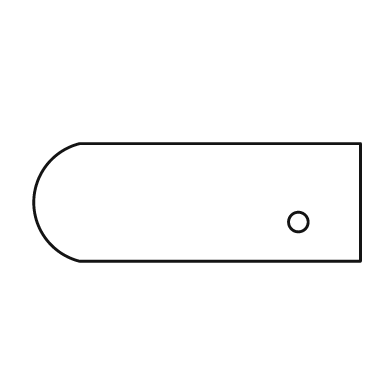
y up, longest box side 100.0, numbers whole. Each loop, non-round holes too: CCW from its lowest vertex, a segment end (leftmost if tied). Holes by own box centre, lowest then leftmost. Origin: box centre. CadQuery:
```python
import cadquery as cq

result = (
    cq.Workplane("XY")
    .moveTo(-36.0, -18.0)
    .lineTo(50.0, -18.0)
    .lineTo(50.0, 18.0)
    .lineTo(-36.0, 18.0)
    .threePointArc((-50.0, 0.0), (-36.0, -18.0))
    .close()
    .moveTo(31.0, -6.0)
    .circle(3.0)
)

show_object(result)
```